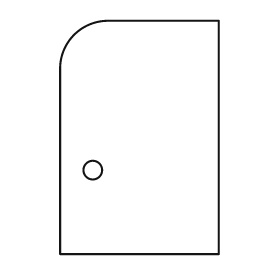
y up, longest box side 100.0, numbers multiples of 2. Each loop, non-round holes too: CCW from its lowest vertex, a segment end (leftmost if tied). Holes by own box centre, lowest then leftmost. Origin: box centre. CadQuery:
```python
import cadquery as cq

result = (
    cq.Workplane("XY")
    .moveTo(-34.0, -50.0)
    .lineTo(34.0, -50.0)
    .lineTo(34.0, 50.0)
    .lineTo(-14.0, 50.0)
    .threePointArc((-28.0, 44.0), (-34.0, 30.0))
    .close()
    .moveTo(-20.0, -14.0)
    .circle(4.0)
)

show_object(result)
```